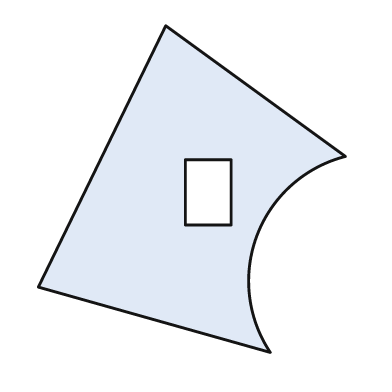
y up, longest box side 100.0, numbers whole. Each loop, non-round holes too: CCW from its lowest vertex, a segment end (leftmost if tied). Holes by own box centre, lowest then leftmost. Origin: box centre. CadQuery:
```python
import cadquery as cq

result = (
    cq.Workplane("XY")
    .moveTo(24.0, -50.0)
    .threePointArc((20.0, -14.0), (47.0, 10.0))
    .lineTo(-8.0, 50.0)
    .lineTo(-47.0, -30.0)
    .close()
    .moveTo(-2.0, -11.0)
    .lineTo(12.0, -11.0)
    .lineTo(12.0, 9.0)
    .lineTo(-2.0, 9.0)
    .close()
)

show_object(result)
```